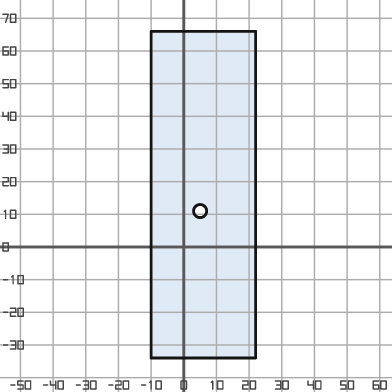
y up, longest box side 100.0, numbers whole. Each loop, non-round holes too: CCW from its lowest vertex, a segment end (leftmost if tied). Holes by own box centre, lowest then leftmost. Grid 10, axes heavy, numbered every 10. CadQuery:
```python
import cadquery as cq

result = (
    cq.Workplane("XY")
    .moveTo(-10.0, -34.0)
    .lineTo(22.0, -34.0)
    .lineTo(22.0, 66.0)
    .lineTo(-10.0, 66.0)
    .close()
    .moveTo(5.0, 11.0)
    .circle(2.0)
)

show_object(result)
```